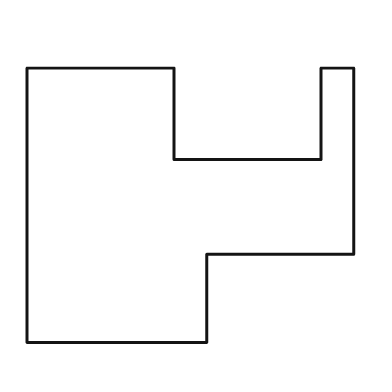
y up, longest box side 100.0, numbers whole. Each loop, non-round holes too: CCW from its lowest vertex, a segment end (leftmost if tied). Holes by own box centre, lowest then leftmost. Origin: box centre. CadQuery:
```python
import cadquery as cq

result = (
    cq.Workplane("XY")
    .moveTo(-50.0, -42.0)
    .lineTo(5.0, -42.0)
    .lineTo(5.0, -15.0)
    .lineTo(50.0, -15.0)
    .lineTo(50.0, 42.0)
    .lineTo(40.0, 42.0)
    .lineTo(40.0, 14.0)
    .lineTo(-5.0, 14.0)
    .lineTo(-5.0, 42.0)
    .lineTo(-50.0, 42.0)
    .close()
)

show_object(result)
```